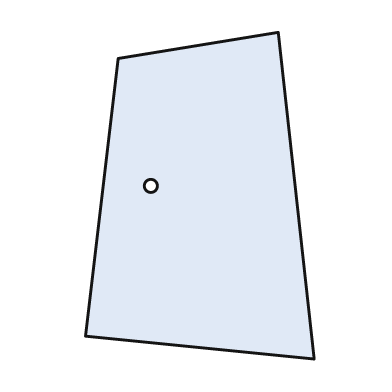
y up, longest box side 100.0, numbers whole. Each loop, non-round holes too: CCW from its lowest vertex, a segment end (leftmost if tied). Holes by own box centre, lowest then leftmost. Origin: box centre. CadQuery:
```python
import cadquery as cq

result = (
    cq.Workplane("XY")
    .moveTo(35.0, -50.0)
    .lineTo(24.0, 50.0)
    .lineTo(-25.0, 42.0)
    .lineTo(-35.0, -43.0)
    .close()
    .moveTo(-15.0, 3.0)
    .circle(2.0)
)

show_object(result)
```